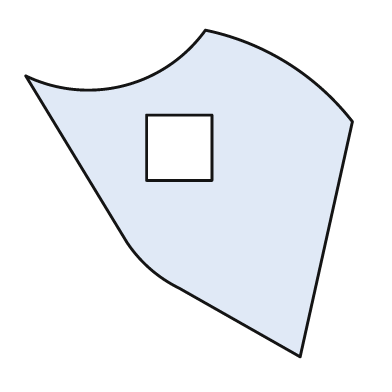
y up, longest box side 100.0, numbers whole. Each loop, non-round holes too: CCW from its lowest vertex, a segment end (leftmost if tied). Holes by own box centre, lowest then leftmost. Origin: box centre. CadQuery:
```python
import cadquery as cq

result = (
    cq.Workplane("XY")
    .moveTo(34.0, -50.0)
    .lineTo(50.0, 22.0)
    .threePointArc((30.0, 40.0), (5.0, 50.0))
    .threePointArc((-20.0, 33.0), (-50.0, 36.0))
    .lineTo(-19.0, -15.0)
    .threePointArc((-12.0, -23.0), (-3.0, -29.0))
    .close()
    .moveTo(-13.0, 4.0)
    .lineTo(7.0, 4.0)
    .lineTo(7.0, 24.0)
    .lineTo(-13.0, 24.0)
    .close()
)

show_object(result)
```